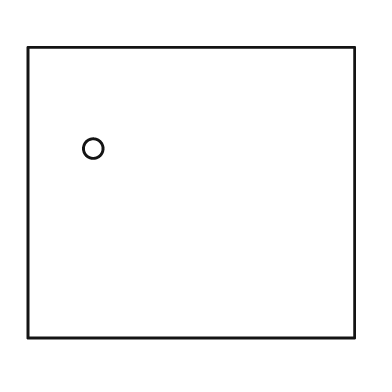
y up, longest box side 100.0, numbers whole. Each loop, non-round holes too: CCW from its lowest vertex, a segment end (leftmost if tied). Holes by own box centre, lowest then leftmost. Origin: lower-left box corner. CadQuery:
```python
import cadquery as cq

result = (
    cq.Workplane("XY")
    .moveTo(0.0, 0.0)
    .lineTo(100.0, 0.0)
    .lineTo(100.0, 89.0)
    .lineTo(0.0, 89.0)
    .close()
    .moveTo(20.0, 58.0)
    .circle(3.0)
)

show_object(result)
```